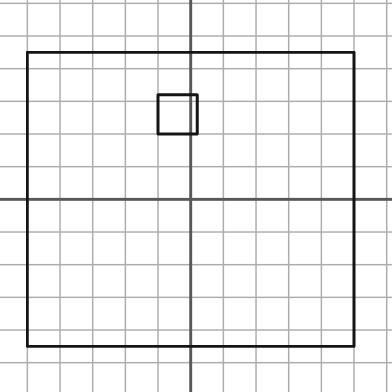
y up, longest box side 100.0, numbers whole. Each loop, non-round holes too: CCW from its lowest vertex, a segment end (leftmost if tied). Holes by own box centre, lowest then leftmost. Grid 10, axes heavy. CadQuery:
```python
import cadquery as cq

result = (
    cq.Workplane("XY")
    .moveTo(-50.0, -45.0)
    .lineTo(50.0, -45.0)
    .lineTo(50.0, 45.0)
    .lineTo(-50.0, 45.0)
    .close()
    .moveTo(-10.0, 20.0)
    .lineTo(2.0, 20.0)
    .lineTo(2.0, 32.0)
    .lineTo(-10.0, 32.0)
    .close()
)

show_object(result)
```